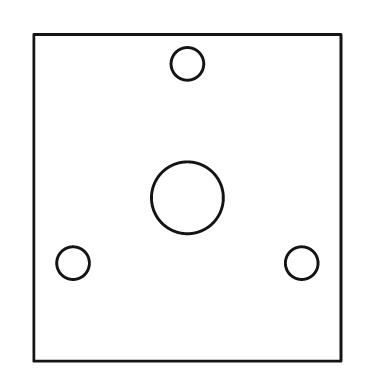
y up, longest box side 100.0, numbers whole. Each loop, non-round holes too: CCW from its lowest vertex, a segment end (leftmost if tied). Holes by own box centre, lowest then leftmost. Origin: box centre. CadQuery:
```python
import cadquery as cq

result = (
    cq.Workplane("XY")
    .moveTo(-47.0, -50.0)
    .lineTo(47.0, -50.0)
    .lineTo(47.0, 50.0)
    .lineTo(-47.0, 50.0)
    .close()
    .moveTo(-35.0, -20.0)
    .circle(5.0)
    .moveTo(35.0, -20.0)
    .circle(5.0)
    .moveTo(0.0, 0.0)
    .circle(11.0)
    .moveTo(0.0, 41.0)
    .circle(5.0)
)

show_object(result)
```